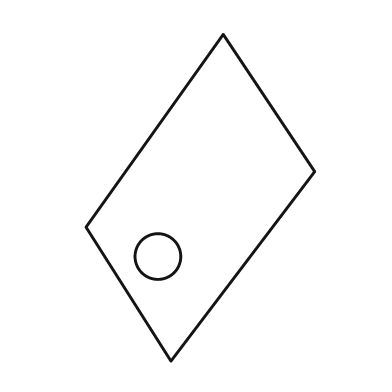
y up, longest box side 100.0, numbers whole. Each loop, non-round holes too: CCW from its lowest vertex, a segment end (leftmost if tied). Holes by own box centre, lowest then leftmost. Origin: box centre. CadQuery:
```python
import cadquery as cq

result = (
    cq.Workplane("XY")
    .moveTo(-9.0, -50.0)
    .lineTo(35.0, 8.0)
    .lineTo(7.0, 50.0)
    .lineTo(-35.0, -9.0)
    .close()
    .moveTo(-13.0, -18.0)
    .circle(7.0)
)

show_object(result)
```